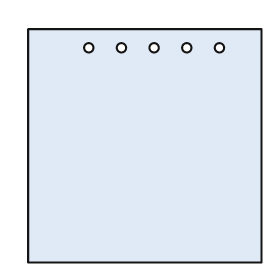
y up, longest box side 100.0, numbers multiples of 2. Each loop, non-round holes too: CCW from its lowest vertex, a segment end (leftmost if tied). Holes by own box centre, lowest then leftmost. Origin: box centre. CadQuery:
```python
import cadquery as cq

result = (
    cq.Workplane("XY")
    .moveTo(-50.0, -50.0)
    .lineTo(50.0, -50.0)
    .lineTo(50.0, 50.0)
    .lineTo(-50.0, 50.0)
    .close()
    .moveTo(-24.0, 42.0)
    .circle(2.0)
    .moveTo(-10.0, 42.0)
    .circle(2.0)
    .moveTo(4.0, 42.0)
    .circle(2.0)
    .moveTo(18.0, 42.0)
    .circle(2.0)
    .moveTo(32.0, 42.0)
    .circle(2.0)
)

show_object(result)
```